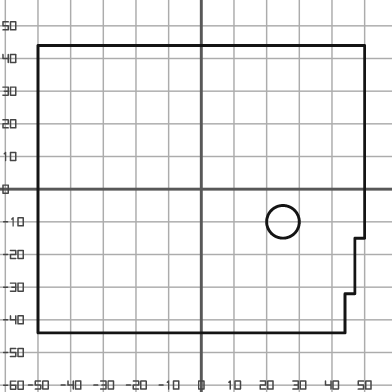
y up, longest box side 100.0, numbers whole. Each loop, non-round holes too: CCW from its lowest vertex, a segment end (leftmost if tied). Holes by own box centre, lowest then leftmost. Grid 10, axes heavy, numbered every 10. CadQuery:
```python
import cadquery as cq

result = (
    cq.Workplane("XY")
    .moveTo(-50.0, -44.0)
    .lineTo(44.0, -44.0)
    .lineTo(44.0, -32.0)
    .lineTo(47.0, -32.0)
    .lineTo(47.0, -15.0)
    .lineTo(50.0, -15.0)
    .lineTo(50.0, 44.0)
    .lineTo(-50.0, 44.0)
    .close()
    .moveTo(25.0, -10.0)
    .circle(5.0)
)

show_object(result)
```